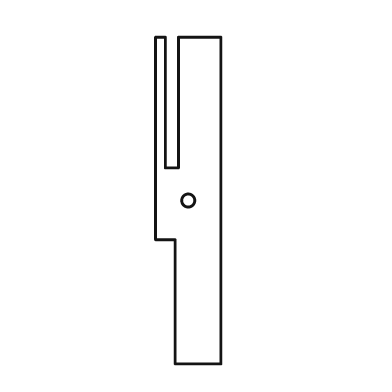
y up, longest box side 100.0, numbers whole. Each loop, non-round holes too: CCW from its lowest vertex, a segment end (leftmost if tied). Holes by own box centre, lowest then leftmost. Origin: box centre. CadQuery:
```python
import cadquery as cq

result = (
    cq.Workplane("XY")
    .moveTo(-4.0, -50.0)
    .lineTo(10.0, -50.0)
    .lineTo(10.0, 50.0)
    .lineTo(-3.0, 50.0)
    .lineTo(-3.0, 10.0)
    .lineTo(-7.0, 10.0)
    .lineTo(-7.0, 50.0)
    .lineTo(-10.0, 50.0)
    .lineTo(-10.0, -12.0)
    .lineTo(-4.0, -12.0)
    .close()
    .moveTo(0.0, 0.0)
    .circle(2.0)
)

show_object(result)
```